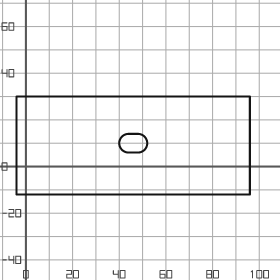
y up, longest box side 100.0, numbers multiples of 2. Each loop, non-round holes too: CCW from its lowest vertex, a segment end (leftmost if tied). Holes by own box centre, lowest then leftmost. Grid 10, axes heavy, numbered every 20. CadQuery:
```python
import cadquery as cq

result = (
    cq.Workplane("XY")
    .moveTo(-4.0, -12.0)
    .lineTo(96.0, -12.0)
    .lineTo(96.0, 30.0)
    .lineTo(-4.0, 30.0)
    .close()
    .moveTo(44.0, 6.0)
    .lineTo(48.0, 6.0)
    .threePointArc((52.0, 10.0), (48.0, 14.0))
    .lineTo(44.0, 14.0)
    .threePointArc((40.0, 10.0), (44.0, 6.0))
    .close()
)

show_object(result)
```